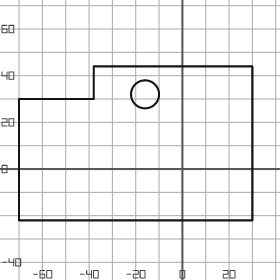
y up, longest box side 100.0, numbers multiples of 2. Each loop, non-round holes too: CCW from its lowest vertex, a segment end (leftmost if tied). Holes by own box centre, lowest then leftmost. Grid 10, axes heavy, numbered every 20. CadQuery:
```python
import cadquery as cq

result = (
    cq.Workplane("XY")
    .moveTo(-70.0, -22.0)
    .lineTo(30.0, -22.0)
    .lineTo(30.0, 44.0)
    .lineTo(-38.0, 44.0)
    .lineTo(-38.0, 30.0)
    .lineTo(-70.0, 30.0)
    .close()
    .moveTo(-16.0, 32.0)
    .circle(6.0)
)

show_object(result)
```